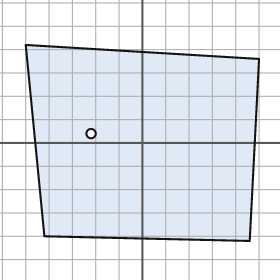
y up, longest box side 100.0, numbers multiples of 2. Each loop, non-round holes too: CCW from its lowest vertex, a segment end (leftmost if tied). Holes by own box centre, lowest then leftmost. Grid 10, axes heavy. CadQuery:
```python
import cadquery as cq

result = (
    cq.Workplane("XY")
    .moveTo(46.0, -42.0)
    .lineTo(50.0, 36.0)
    .lineTo(-50.0, 42.0)
    .lineTo(-42.0, -40.0)
    .close()
    .moveTo(-22.0, 4.0)
    .circle(2.0)
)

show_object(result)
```